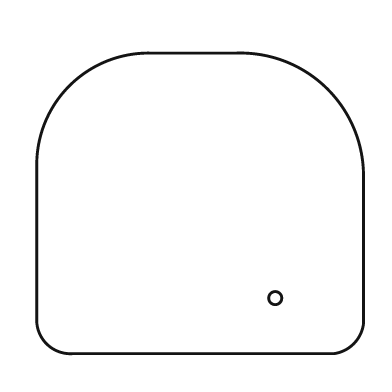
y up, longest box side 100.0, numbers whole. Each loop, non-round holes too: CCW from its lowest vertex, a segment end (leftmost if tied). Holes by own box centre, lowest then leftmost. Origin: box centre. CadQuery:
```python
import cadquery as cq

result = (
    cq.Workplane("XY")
    .moveTo(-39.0, -46.0)
    .lineTo(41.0, -46.0)
    .threePointArc((47.0, -43.0), (50.0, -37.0))
    .lineTo(50.0, 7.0)
    .threePointArc((39.0, 35.0), (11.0, 46.0))
    .lineTo(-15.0, 46.0)
    .threePointArc((-40.0, 36.0), (-50.0, 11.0))
    .lineTo(-50.0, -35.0)
    .threePointArc((-47.0, -43.0), (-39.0, -46.0))
    .close()
    .moveTo(23.0, -29.0)
    .circle(2.0)
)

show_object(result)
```